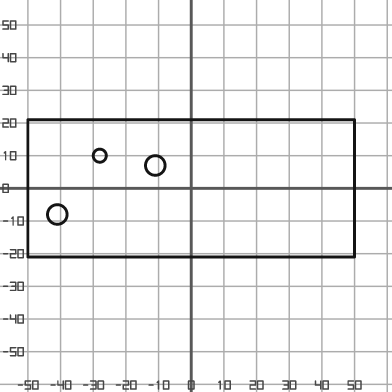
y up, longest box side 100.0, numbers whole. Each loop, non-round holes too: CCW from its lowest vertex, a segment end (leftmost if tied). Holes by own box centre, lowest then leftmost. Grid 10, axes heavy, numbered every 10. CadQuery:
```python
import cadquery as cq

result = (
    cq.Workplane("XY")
    .moveTo(-50.0, -21.0)
    .lineTo(50.0, -21.0)
    .lineTo(50.0, 21.0)
    .lineTo(-50.0, 21.0)
    .close()
    .moveTo(-41.0, -8.0)
    .circle(3.0)
    .moveTo(-11.0, 7.0)
    .circle(3.0)
    .moveTo(-28.0, 10.0)
    .circle(2.0)
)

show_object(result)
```